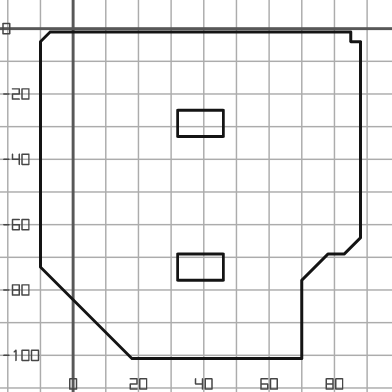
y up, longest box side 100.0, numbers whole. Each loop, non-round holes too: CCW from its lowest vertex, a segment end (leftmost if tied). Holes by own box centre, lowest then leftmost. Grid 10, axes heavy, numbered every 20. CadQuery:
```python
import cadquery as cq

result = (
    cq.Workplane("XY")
    .moveTo(18.0, -101.0)
    .lineTo(70.0, -101.0)
    .lineTo(70.0, -77.0)
    .lineTo(78.0, -69.0)
    .lineTo(83.0, -69.0)
    .lineTo(88.0, -64.0)
    .lineTo(88.0, -4.0)
    .lineTo(85.0, -4.0)
    .lineTo(85.0, -1.0)
    .lineTo(-7.0, -1.0)
    .lineTo(-10.0, -4.0)
    .lineTo(-10.0, -73.0)
    .close()
    .moveTo(32.0, -77.0)
    .lineTo(46.0, -77.0)
    .lineTo(46.0, -69.0)
    .lineTo(32.0, -69.0)
    .close()
    .moveTo(32.0, -33.0)
    .lineTo(46.0, -33.0)
    .lineTo(46.0, -25.0)
    .lineTo(32.0, -25.0)
    .close()
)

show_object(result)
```